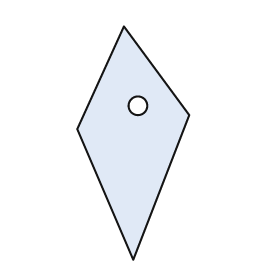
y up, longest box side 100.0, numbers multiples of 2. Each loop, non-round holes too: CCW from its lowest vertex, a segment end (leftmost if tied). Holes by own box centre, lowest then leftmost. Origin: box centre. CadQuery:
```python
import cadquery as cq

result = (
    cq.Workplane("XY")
    .moveTo(0.0, -50.0)
    .lineTo(24.0, 12.0)
    .lineTo(-4.0, 50.0)
    .lineTo(-24.0, 6.0)
    .close()
    .moveTo(2.0, 16.0)
    .circle(4.0)
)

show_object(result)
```